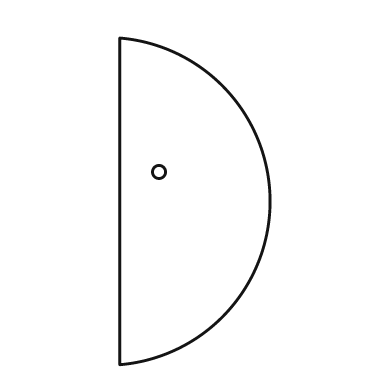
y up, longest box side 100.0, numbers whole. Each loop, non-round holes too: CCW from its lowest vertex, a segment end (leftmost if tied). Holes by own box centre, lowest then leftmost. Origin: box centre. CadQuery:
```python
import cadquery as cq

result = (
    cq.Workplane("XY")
    .moveTo(-23.0, -50.0)
    .threePointArc((23.0, 0.0), (-23.0, 50.0))
    .close()
    .moveTo(-11.0, 9.0)
    .circle(2.0)
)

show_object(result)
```